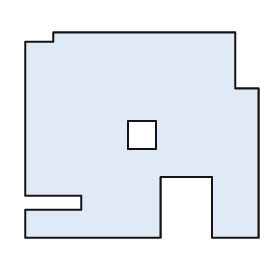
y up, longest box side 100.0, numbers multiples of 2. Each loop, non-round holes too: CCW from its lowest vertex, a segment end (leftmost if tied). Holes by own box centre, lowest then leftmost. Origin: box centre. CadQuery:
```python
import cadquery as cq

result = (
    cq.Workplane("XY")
    .moveTo(-50.0, -44.0)
    .lineTo(8.0, -44.0)
    .lineTo(8.0, -18.0)
    .lineTo(30.0, -18.0)
    .lineTo(30.0, -44.0)
    .lineTo(50.0, -44.0)
    .lineTo(50.0, 20.0)
    .lineTo(40.0, 20.0)
    .lineTo(40.0, 44.0)
    .lineTo(-38.0, 44.0)
    .lineTo(-38.0, 40.0)
    .lineTo(-50.0, 40.0)
    .lineTo(-50.0, -26.0)
    .lineTo(-26.0, -26.0)
    .lineTo(-26.0, -32.0)
    .lineTo(-50.0, -32.0)
    .close()
    .moveTo(-6.0, -6.0)
    .lineTo(6.0, -6.0)
    .lineTo(6.0, 6.0)
    .lineTo(-6.0, 6.0)
    .close()
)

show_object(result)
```